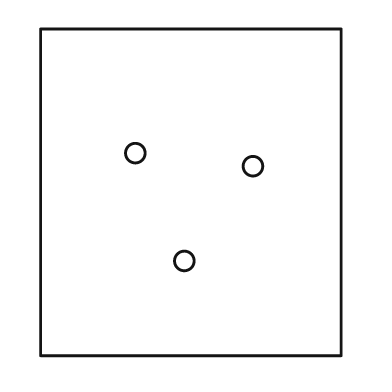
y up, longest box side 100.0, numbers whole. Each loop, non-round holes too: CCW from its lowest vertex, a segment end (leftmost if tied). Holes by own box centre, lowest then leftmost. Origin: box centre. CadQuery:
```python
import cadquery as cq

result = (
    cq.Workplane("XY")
    .moveTo(-46.0, -50.0)
    .lineTo(46.0, -50.0)
    .lineTo(46.0, 50.0)
    .lineTo(-46.0, 50.0)
    .close()
    .moveTo(-2.0, -21.0)
    .circle(3.0)
    .moveTo(19.0, 8.0)
    .circle(3.0)
    .moveTo(-17.0, 12.0)
    .circle(3.0)
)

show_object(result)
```